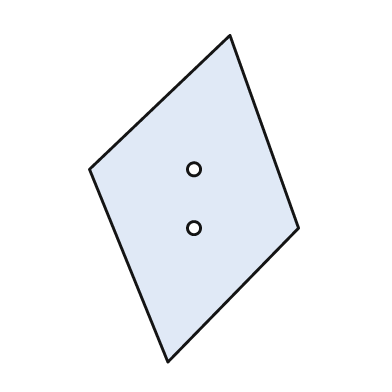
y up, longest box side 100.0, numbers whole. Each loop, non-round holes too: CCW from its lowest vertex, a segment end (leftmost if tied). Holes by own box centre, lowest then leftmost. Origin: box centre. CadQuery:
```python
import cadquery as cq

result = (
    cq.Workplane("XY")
    .moveTo(-8.0, -50.0)
    .lineTo(32.0, -9.0)
    .lineTo(11.0, 50.0)
    .lineTo(-32.0, 9.0)
    .close()
    .moveTo(0.0, -9.0)
    .circle(2.0)
    .moveTo(0.0, 9.0)
    .circle(2.0)
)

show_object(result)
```